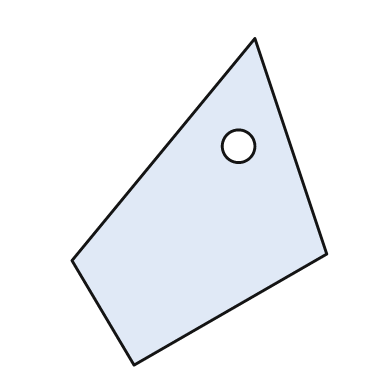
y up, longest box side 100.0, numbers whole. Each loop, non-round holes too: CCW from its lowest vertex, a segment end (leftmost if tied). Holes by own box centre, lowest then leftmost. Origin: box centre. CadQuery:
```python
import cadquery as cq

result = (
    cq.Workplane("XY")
    .moveTo(-20.0, -50.0)
    .lineTo(39.0, -16.0)
    .lineTo(17.0, 50.0)
    .lineTo(-39.0, -18.0)
    .close()
    .moveTo(12.0, 17.0)
    .circle(5.0)
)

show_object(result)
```